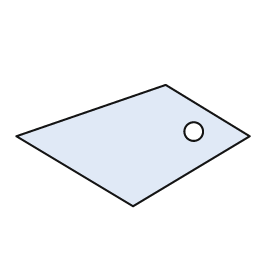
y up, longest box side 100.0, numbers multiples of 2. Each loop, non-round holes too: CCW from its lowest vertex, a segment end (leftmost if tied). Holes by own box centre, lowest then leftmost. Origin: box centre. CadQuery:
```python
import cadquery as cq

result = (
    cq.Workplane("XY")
    .moveTo(0.0, -26.0)
    .lineTo(50.0, 4.0)
    .lineTo(14.0, 26.0)
    .lineTo(-50.0, 4.0)
    .close()
    .moveTo(26.0, 6.0)
    .circle(4.0)
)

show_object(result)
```